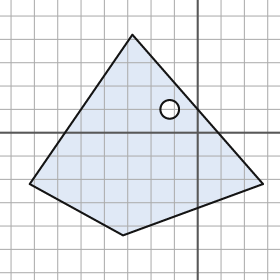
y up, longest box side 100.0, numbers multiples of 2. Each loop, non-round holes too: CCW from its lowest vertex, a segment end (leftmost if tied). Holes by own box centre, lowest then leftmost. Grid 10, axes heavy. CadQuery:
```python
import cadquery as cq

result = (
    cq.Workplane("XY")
    .moveTo(-32.0, -44.0)
    .lineTo(28.0, -22.0)
    .lineTo(-28.0, 42.0)
    .lineTo(-72.0, -22.0)
    .close()
    .moveTo(-12.0, 10.0)
    .circle(4.0)
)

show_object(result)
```